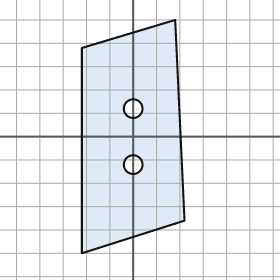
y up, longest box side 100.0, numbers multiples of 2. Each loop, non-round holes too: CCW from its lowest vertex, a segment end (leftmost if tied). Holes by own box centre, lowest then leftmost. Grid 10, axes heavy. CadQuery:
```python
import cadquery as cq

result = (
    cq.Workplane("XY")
    .moveTo(-22.0, -50.0)
    .lineTo(22.0, -36.0)
    .lineTo(18.0, 50.0)
    .lineTo(-22.0, 38.0)
    .close()
    .moveTo(0.0, -12.0)
    .circle(4.0)
    .moveTo(0.0, 12.0)
    .circle(4.0)
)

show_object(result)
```